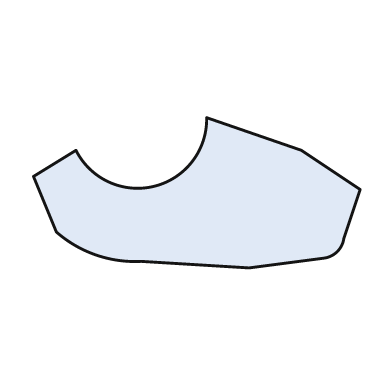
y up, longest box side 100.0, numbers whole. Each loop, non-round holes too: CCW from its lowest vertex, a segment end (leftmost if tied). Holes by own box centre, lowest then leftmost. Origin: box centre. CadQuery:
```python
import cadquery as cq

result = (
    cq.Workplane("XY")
    .moveTo(16.0, -23.0)
    .lineTo(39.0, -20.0)
    .threePointArc((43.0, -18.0), (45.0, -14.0))
    .lineTo(50.0, 1.0)
    .lineTo(32.0, 13.0)
    .lineTo(3.0, 23.0)
    .threePointArc((-13.0, 2.0), (-37.0, 13.0))
    .lineTo(-50.0, 5.0)
    .lineTo(-43.0, -12.0)
    .threePointArc((-31.0, -19.0), (-17.0, -21.0))
    .close()
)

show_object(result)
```